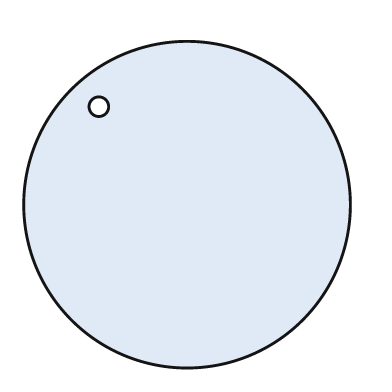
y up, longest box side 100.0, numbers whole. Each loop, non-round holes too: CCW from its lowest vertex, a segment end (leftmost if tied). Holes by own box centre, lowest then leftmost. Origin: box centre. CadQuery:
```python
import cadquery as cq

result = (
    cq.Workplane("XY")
    .moveTo(0.0, 0.0)
    .circle(50.0)
    .moveTo(-27.0, 30.0)
    .circle(3.0)
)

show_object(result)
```